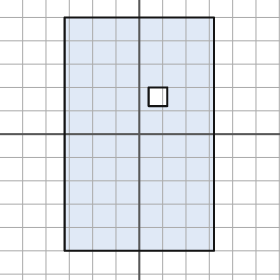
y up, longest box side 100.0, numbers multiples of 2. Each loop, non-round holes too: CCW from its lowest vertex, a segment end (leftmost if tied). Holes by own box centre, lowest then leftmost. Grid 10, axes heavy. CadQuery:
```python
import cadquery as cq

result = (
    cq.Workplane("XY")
    .moveTo(-32.0, -50.0)
    .lineTo(32.0, -50.0)
    .lineTo(32.0, 50.0)
    .lineTo(-32.0, 50.0)
    .close()
    .moveTo(4.0, 12.0)
    .lineTo(12.0, 12.0)
    .lineTo(12.0, 20.0)
    .lineTo(4.0, 20.0)
    .close()
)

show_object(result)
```